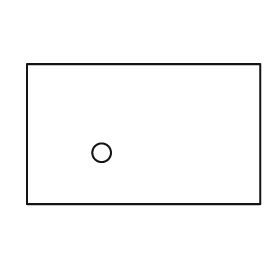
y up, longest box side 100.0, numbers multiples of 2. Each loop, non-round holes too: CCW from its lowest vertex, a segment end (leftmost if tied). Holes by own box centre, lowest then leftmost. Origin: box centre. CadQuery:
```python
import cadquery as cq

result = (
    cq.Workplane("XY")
    .moveTo(-50.0, -30.0)
    .lineTo(50.0, -30.0)
    .lineTo(50.0, 30.0)
    .lineTo(-50.0, 30.0)
    .close()
    .moveTo(-18.0, -8.0)
    .circle(4.0)
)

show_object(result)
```